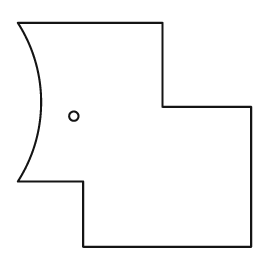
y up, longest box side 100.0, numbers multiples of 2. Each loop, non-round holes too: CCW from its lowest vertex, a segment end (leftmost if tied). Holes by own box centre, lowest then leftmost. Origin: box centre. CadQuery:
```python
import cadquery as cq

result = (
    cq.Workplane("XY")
    .moveTo(-22.0, -48.0)
    .lineTo(50.0, -48.0)
    .lineTo(50.0, 12.0)
    .lineTo(12.0, 12.0)
    .lineTo(12.0, 48.0)
    .lineTo(-50.0, 48.0)
    .threePointArc((-40.0, 14.0), (-50.0, -20.0))
    .lineTo(-22.0, -20.0)
    .close()
    .moveTo(-26.0, 8.0)
    .circle(2.0)
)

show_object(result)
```